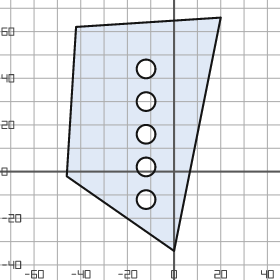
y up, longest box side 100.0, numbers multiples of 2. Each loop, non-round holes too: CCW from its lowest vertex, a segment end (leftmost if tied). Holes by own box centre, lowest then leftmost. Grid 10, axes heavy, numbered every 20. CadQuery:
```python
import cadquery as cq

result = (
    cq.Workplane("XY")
    .moveTo(0.0, -34.0)
    .lineTo(20.0, 66.0)
    .lineTo(-42.0, 62.0)
    .lineTo(-46.0, -2.0)
    .close()
    .moveTo(-12.0, -12.0)
    .circle(4.0)
    .moveTo(-12.0, 2.0)
    .circle(4.0)
    .moveTo(-12.0, 16.0)
    .circle(4.0)
    .moveTo(-12.0, 30.0)
    .circle(4.0)
    .moveTo(-12.0, 44.0)
    .circle(4.0)
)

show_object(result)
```